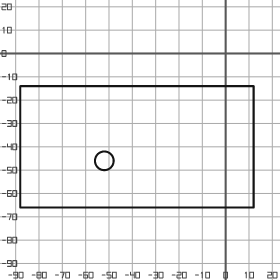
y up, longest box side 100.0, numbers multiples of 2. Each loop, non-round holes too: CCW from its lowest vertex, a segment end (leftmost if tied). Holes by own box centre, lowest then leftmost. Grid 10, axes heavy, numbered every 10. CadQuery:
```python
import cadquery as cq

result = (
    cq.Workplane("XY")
    .moveTo(-88.0, -66.0)
    .lineTo(12.0, -66.0)
    .lineTo(12.0, -14.0)
    .lineTo(-88.0, -14.0)
    .close()
    .moveTo(-52.0, -46.0)
    .circle(4.0)
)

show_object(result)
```